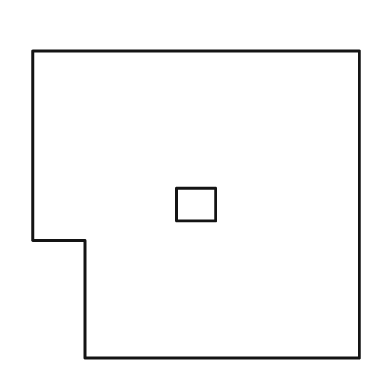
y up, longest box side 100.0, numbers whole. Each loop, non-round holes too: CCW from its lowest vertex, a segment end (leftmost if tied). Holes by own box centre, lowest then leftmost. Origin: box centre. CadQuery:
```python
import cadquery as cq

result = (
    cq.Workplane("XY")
    .moveTo(-34.0, -47.0)
    .lineTo(50.0, -47.0)
    .lineTo(50.0, 47.0)
    .lineTo(-50.0, 47.0)
    .lineTo(-50.0, -11.0)
    .lineTo(-34.0, -11.0)
    .close()
    .moveTo(-6.0, -5.0)
    .lineTo(6.0, -5.0)
    .lineTo(6.0, 5.0)
    .lineTo(-6.0, 5.0)
    .close()
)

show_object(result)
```